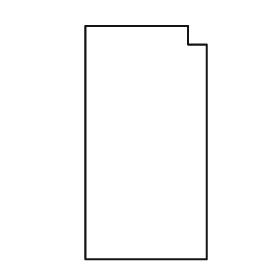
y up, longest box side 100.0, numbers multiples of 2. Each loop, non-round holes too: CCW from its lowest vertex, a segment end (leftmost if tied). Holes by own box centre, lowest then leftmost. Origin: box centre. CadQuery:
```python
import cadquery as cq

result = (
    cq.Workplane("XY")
    .moveTo(-26.0, -50.0)
    .lineTo(26.0, -50.0)
    .lineTo(26.0, 42.0)
    .lineTo(18.0, 42.0)
    .lineTo(18.0, 50.0)
    .lineTo(-26.0, 50.0)
    .close()
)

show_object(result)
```